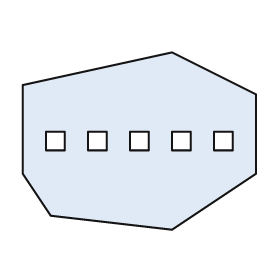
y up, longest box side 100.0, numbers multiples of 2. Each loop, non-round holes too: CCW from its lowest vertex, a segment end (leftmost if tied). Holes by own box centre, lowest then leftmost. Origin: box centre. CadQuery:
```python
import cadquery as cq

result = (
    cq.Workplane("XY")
    .moveTo(14.0, -38.0)
    .lineTo(50.0, -14.0)
    .lineTo(50.0, 20.0)
    .lineTo(14.0, 38.0)
    .lineTo(-50.0, 24.0)
    .lineTo(-50.0, -14.0)
    .lineTo(-38.0, -32.0)
    .close()
    .moveTo(-40.0, -4.0)
    .lineTo(-32.0, -4.0)
    .lineTo(-32.0, 4.0)
    .lineTo(-40.0, 4.0)
    .close()
    .moveTo(-22.0, -4.0)
    .lineTo(-14.0, -4.0)
    .lineTo(-14.0, 4.0)
    .lineTo(-22.0, 4.0)
    .close()
    .moveTo(-4.0, -4.0)
    .lineTo(4.0, -4.0)
    .lineTo(4.0, 4.0)
    .lineTo(-4.0, 4.0)
    .close()
    .moveTo(14.0, -4.0)
    .lineTo(22.0, -4.0)
    .lineTo(22.0, 4.0)
    .lineTo(14.0, 4.0)
    .close()
    .moveTo(32.0, -4.0)
    .lineTo(40.0, -4.0)
    .lineTo(40.0, 4.0)
    .lineTo(32.0, 4.0)
    .close()
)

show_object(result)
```